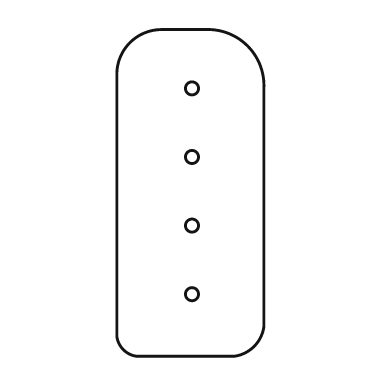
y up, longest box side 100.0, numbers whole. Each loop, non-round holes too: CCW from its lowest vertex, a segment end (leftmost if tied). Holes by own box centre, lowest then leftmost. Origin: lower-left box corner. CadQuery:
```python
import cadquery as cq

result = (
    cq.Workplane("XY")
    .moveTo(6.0, 0.0)
    .lineTo(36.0, 0.0)
    .threePointArc((42.0, 3.0), (45.0, 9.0))
    .lineTo(45.0, 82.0)
    .threePointArc((40.0, 95.0), (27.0, 100.0))
    .lineTo(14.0, 100.0)
    .threePointArc((4.0, 96.0), (0.0, 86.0))
    .lineTo(0.0, 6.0)
    .threePointArc((2.0, 2.0), (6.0, 0.0))
    .close()
    .moveTo(23.0, 19.0)
    .circle(2.0)
    .moveTo(23.0, 40.0)
    .circle(2.0)
    .moveTo(23.0, 61.0)
    .circle(2.0)
    .moveTo(23.0, 82.0)
    .circle(2.0)
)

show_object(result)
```